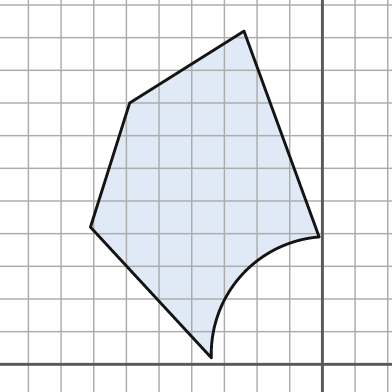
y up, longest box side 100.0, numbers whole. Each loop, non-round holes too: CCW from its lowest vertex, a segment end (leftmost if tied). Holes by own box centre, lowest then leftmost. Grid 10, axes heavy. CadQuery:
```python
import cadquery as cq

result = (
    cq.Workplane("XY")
    .moveTo(-34.0, 2.0)
    .threePointArc((-25.0, 27.0), (-1.0, 39.0))
    .lineTo(-24.0, 102.0)
    .lineTo(-59.0, 80.0)
    .lineTo(-71.0, 42.0)
    .close()
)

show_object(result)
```